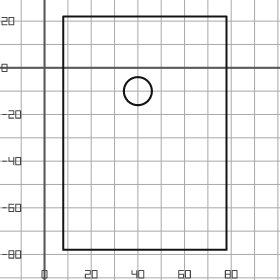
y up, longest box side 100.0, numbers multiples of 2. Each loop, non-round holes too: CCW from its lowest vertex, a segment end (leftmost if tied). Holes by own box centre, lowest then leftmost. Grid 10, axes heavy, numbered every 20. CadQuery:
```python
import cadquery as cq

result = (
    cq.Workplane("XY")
    .moveTo(8.0, -78.0)
    .lineTo(78.0, -78.0)
    .lineTo(78.0, 22.0)
    .lineTo(8.0, 22.0)
    .close()
    .moveTo(40.0, -10.0)
    .circle(6.0)
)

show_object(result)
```